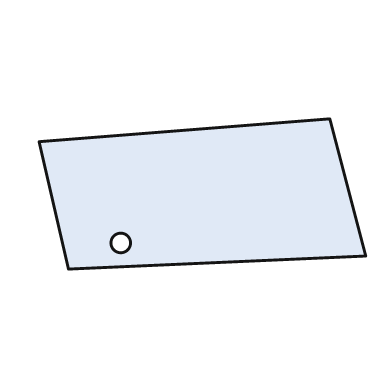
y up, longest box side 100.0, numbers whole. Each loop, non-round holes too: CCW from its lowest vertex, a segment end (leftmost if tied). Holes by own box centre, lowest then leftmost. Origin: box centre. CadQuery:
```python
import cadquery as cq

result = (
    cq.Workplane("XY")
    .moveTo(-41.0, -23.0)
    .lineTo(50.0, -19.0)
    .lineTo(39.0, 23.0)
    .lineTo(-50.0, 16.0)
    .close()
    .moveTo(-25.0, -15.0)
    .circle(3.0)
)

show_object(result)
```